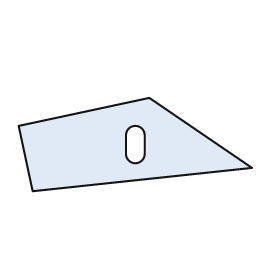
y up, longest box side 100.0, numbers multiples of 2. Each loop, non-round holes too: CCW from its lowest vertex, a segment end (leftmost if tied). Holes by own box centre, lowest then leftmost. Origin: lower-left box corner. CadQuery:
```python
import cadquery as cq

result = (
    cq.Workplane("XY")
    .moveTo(6.0, 0.0)
    .lineTo(100.0, 10.0)
    .lineTo(56.0, 40.0)
    .lineTo(0.0, 28.0)
    .close()
    .moveTo(46.0, 16.0)
    .threePointArc((50.0, 12.0), (54.0, 16.0))
    .lineTo(54.0, 24.0)
    .threePointArc((50.0, 28.0), (46.0, 24.0))
    .close()
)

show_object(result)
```